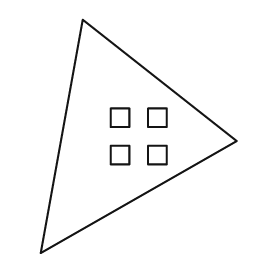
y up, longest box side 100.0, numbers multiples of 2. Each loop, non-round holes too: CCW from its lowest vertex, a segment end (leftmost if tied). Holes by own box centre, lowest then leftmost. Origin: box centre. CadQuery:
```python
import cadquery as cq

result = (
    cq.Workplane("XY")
    .moveTo(-42.0, -50.0)
    .lineTo(42.0, -2.0)
    .lineTo(-24.0, 50.0)
    .close()
    .moveTo(-12.0, -12.0)
    .lineTo(-4.0, -12.0)
    .lineTo(-4.0, -4.0)
    .lineTo(-12.0, -4.0)
    .close()
    .moveTo(4.0, -12.0)
    .lineTo(12.0, -12.0)
    .lineTo(12.0, -4.0)
    .lineTo(4.0, -4.0)
    .close()
    .moveTo(-12.0, 4.0)
    .lineTo(-4.0, 4.0)
    .lineTo(-4.0, 12.0)
    .lineTo(-12.0, 12.0)
    .close()
    .moveTo(4.0, 4.0)
    .lineTo(12.0, 4.0)
    .lineTo(12.0, 12.0)
    .lineTo(4.0, 12.0)
    .close()
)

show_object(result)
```